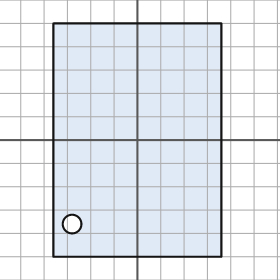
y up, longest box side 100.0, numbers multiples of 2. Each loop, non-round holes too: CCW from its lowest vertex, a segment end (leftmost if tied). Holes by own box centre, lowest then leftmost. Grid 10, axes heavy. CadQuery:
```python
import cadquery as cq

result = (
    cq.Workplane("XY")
    .moveTo(-36.0, -50.0)
    .lineTo(36.0, -50.0)
    .lineTo(36.0, 50.0)
    .lineTo(-36.0, 50.0)
    .close()
    .moveTo(-28.0, -36.0)
    .circle(4.0)
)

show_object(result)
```